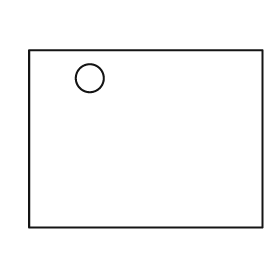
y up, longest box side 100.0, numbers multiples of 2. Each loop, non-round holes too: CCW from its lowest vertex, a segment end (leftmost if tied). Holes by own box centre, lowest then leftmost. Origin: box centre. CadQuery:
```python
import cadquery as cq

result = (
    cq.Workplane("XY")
    .moveTo(-50.0, -38.0)
    .lineTo(50.0, -38.0)
    .lineTo(50.0, 38.0)
    .lineTo(-50.0, 38.0)
    .close()
    .moveTo(-24.0, 26.0)
    .circle(6.0)
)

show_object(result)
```